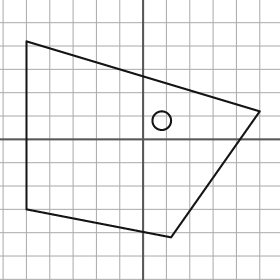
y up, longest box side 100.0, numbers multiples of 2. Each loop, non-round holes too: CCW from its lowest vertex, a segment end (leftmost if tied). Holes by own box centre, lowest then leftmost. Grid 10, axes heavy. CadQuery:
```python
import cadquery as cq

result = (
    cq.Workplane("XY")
    .moveTo(12.0, -42.0)
    .lineTo(50.0, 12.0)
    .lineTo(-50.0, 42.0)
    .lineTo(-50.0, -30.0)
    .close()
    .moveTo(8.0, 8.0)
    .circle(4.0)
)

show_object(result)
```